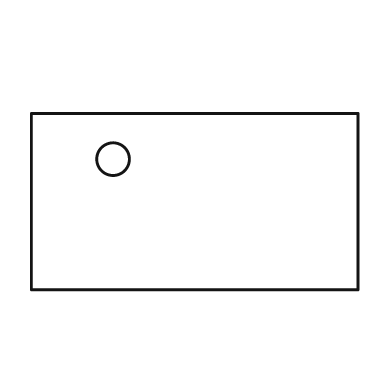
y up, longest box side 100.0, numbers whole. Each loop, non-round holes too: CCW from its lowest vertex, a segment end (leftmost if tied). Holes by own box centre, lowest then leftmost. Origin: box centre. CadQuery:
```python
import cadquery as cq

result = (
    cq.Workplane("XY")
    .moveTo(-50.0, -27.0)
    .lineTo(50.0, -27.0)
    .lineTo(50.0, 27.0)
    .lineTo(-50.0, 27.0)
    .close()
    .moveTo(-25.0, 13.0)
    .circle(5.0)
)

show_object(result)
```